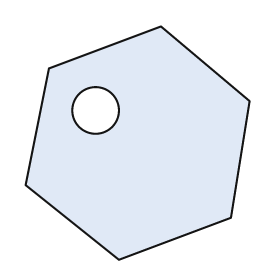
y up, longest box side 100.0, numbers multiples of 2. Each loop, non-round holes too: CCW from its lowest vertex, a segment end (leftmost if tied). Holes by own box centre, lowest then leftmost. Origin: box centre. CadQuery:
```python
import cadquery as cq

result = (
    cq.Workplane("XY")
    .moveTo(-8.0, -50.0)
    .lineTo(40.0, -32.0)
    .lineTo(48.0, 18.0)
    .lineTo(10.0, 50.0)
    .lineTo(-38.0, 32.0)
    .lineTo(-48.0, -18.0)
    .close()
    .moveTo(-18.0, 14.0)
    .circle(10.0)
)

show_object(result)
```